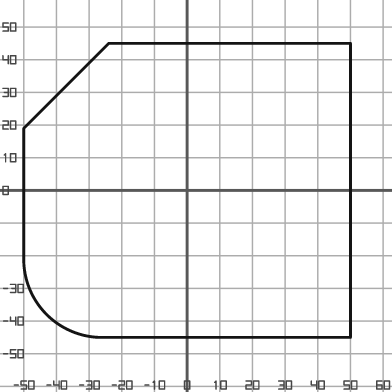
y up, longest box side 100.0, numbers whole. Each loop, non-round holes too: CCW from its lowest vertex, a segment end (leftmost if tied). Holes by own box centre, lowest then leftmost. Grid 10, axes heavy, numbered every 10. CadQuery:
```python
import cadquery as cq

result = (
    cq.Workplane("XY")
    .moveTo(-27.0, -45.0)
    .lineTo(50.0, -45.0)
    .lineTo(50.0, 45.0)
    .lineTo(-24.0, 45.0)
    .lineTo(-50.0, 19.0)
    .lineTo(-50.0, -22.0)
    .threePointArc((-43.0, -38.0), (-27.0, -45.0))
    .close()
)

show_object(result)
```